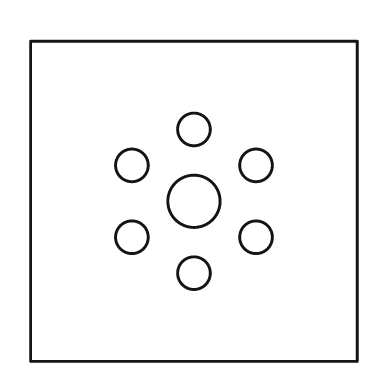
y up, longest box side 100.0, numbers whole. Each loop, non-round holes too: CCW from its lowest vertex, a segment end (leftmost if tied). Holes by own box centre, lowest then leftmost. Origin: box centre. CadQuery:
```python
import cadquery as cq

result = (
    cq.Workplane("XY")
    .moveTo(-50.0, -49.0)
    .lineTo(50.0, -49.0)
    .lineTo(50.0, 49.0)
    .lineTo(-50.0, 49.0)
    .close()
    .moveTo(0.0, -22.0)
    .circle(5.0)
    .moveTo(-19.0, -11.0)
    .circle(5.0)
    .moveTo(19.0, -11.0)
    .circle(5.0)
    .moveTo(0.0, 0.0)
    .circle(8.0)
    .moveTo(-19.0, 11.0)
    .circle(5.0)
    .moveTo(19.0, 11.0)
    .circle(5.0)
    .moveTo(0.0, 22.0)
    .circle(5.0)
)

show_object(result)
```